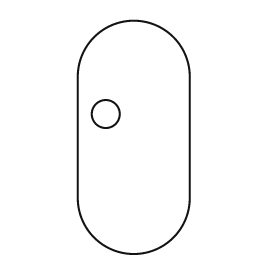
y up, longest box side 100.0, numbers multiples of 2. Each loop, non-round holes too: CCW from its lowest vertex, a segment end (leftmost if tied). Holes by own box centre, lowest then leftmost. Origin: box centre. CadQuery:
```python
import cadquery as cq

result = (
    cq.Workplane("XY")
    .moveTo(-24.0, -26.0)
    .threePointArc((0.0, -50.0), (24.0, -26.0))
    .lineTo(24.0, 26.0)
    .threePointArc((0.0, 50.0), (-24.0, 26.0))
    .close()
    .moveTo(-12.0, 10.0)
    .circle(6.0)
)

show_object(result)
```